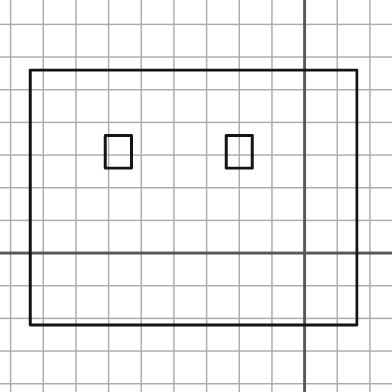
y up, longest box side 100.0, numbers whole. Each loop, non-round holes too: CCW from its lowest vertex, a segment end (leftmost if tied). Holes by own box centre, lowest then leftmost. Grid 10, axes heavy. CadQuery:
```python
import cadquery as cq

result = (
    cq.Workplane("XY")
    .moveTo(-84.0, -22.0)
    .lineTo(16.0, -22.0)
    .lineTo(16.0, 56.0)
    .lineTo(-84.0, 56.0)
    .close()
    .moveTo(-61.0, 26.0)
    .lineTo(-53.0, 26.0)
    .lineTo(-53.0, 36.0)
    .lineTo(-61.0, 36.0)
    .close()
    .moveTo(-24.0, 26.0)
    .lineTo(-16.0, 26.0)
    .lineTo(-16.0, 36.0)
    .lineTo(-24.0, 36.0)
    .close()
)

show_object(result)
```